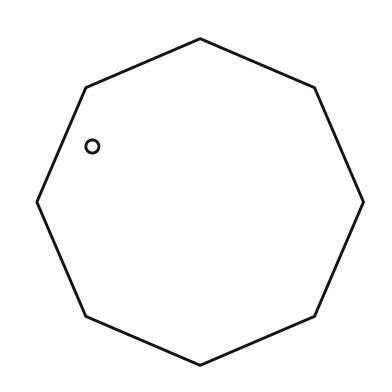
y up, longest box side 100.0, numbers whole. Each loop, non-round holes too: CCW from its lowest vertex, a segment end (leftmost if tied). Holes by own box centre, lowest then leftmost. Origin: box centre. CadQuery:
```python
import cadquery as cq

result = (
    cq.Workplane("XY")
    .moveTo(0.0, -50.0)
    .lineTo(35.0, -35.0)
    .lineTo(50.0, 0.0)
    .lineTo(35.0, 35.0)
    .lineTo(0.0, 50.0)
    .lineTo(-35.0, 35.0)
    .lineTo(-50.0, 0.0)
    .lineTo(-35.0, -35.0)
    .close()
    .moveTo(-33.0, 17.0)
    .circle(2.0)
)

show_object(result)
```